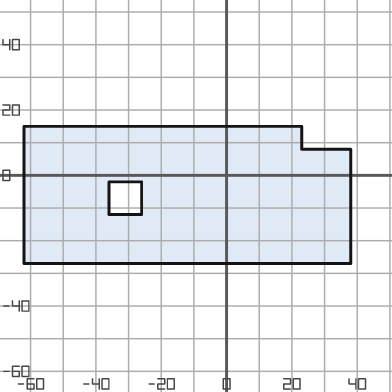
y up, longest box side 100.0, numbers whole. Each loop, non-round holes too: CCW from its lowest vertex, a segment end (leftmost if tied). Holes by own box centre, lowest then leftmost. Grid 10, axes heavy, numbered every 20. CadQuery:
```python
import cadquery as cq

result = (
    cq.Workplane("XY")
    .moveTo(-62.0, -27.0)
    .lineTo(38.0, -27.0)
    .lineTo(38.0, 8.0)
    .lineTo(23.0, 8.0)
    .lineTo(23.0, 15.0)
    .lineTo(-62.0, 15.0)
    .close()
    .moveTo(-36.0, -12.0)
    .lineTo(-26.0, -12.0)
    .lineTo(-26.0, -2.0)
    .lineTo(-36.0, -2.0)
    .close()
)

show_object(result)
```